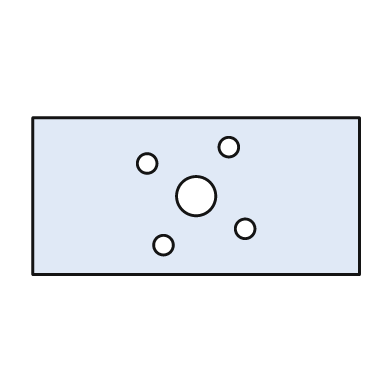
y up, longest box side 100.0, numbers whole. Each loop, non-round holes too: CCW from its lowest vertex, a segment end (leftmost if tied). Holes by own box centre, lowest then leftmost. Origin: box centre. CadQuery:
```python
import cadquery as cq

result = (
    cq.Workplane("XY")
    .moveTo(-50.0, -24.0)
    .lineTo(50.0, -24.0)
    .lineTo(50.0, 24.0)
    .lineTo(-50.0, 24.0)
    .close()
    .moveTo(-10.0, -15.0)
    .circle(3.0)
    .moveTo(15.0, -10.0)
    .circle(3.0)
    .moveTo(0.0, 0.0)
    .circle(6.0)
    .moveTo(-15.0, 10.0)
    .circle(3.0)
    .moveTo(10.0, 15.0)
    .circle(3.0)
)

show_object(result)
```